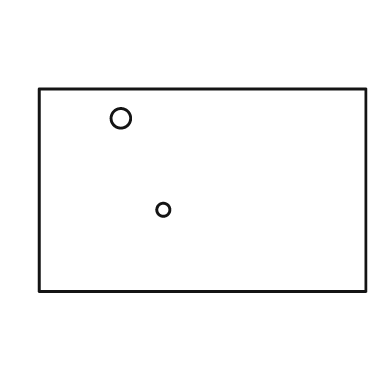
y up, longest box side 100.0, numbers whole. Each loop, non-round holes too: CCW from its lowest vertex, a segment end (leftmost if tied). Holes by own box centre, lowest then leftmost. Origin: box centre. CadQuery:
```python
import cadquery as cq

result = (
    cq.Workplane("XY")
    .moveTo(-50.0, -31.0)
    .lineTo(50.0, -31.0)
    .lineTo(50.0, 31.0)
    .lineTo(-50.0, 31.0)
    .close()
    .moveTo(-12.0, -6.0)
    .circle(2.0)
    .moveTo(-25.0, 22.0)
    .circle(3.0)
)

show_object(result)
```